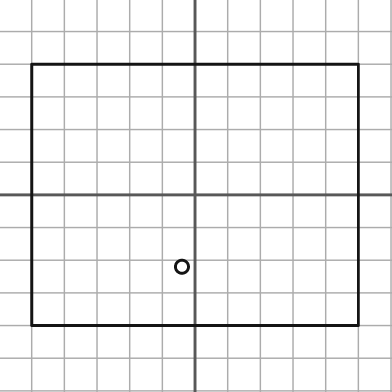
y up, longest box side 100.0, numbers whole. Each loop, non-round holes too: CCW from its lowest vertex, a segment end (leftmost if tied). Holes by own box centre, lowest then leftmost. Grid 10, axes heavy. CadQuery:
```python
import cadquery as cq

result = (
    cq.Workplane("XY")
    .moveTo(-50.0, -40.0)
    .lineTo(50.0, -40.0)
    .lineTo(50.0, 40.0)
    .lineTo(-50.0, 40.0)
    .close()
    .moveTo(-4.0, -22.0)
    .circle(2.0)
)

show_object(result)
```